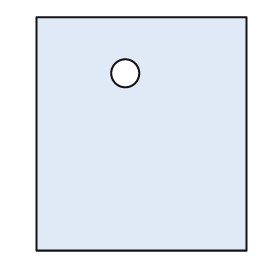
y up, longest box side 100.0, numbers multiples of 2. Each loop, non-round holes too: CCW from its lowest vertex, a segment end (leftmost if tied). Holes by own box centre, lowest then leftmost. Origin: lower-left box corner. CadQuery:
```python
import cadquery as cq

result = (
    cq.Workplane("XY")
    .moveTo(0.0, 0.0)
    .lineTo(90.0, 0.0)
    .lineTo(90.0, 100.0)
    .lineTo(0.0, 100.0)
    .close()
    .moveTo(38.0, 76.0)
    .circle(6.0)
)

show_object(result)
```